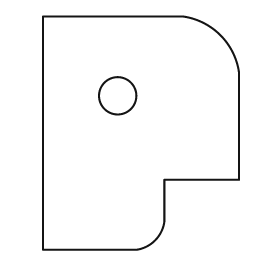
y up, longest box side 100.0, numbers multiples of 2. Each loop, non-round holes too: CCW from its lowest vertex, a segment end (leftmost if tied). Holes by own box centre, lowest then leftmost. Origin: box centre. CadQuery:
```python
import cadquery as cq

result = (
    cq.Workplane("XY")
    .moveTo(-42.0, -50.0)
    .lineTo(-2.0, -50.0)
    .threePointArc((6.0, -46.0), (10.0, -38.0))
    .lineTo(10.0, -20.0)
    .lineTo(42.0, -20.0)
    .lineTo(42.0, 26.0)
    .threePointArc((34.0, 42.0), (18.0, 50.0))
    .lineTo(-42.0, 50.0)
    .close()
    .moveTo(-10.0, 16.0)
    .circle(8.0)
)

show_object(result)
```